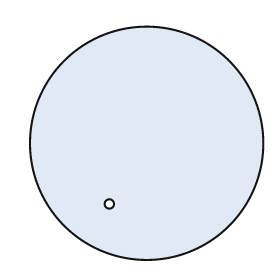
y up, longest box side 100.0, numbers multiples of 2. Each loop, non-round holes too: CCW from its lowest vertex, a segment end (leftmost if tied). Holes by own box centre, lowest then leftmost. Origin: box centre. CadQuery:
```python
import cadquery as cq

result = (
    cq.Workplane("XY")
    .moveTo(0.0, 0.0)
    .circle(50.0)
    .moveTo(-16.0, -26.0)
    .circle(2.0)
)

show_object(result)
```